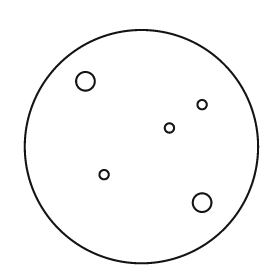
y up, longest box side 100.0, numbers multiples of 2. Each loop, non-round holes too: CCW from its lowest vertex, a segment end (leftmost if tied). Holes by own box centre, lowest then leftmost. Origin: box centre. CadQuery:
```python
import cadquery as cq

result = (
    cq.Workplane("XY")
    .moveTo(0.0, 0.0)
    .circle(50.0)
    .moveTo(26.0, -24.0)
    .circle(4.0)
    .moveTo(-16.0, -12.0)
    .circle(2.0)
    .moveTo(12.0, 8.0)
    .circle(2.0)
    .moveTo(26.0, 18.0)
    .circle(2.0)
    .moveTo(-24.0, 28.0)
    .circle(4.0)
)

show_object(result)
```